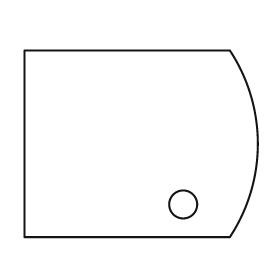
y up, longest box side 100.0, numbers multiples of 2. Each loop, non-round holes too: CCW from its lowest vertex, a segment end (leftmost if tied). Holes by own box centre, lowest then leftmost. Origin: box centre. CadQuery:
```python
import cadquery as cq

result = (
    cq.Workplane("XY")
    .moveTo(-50.0, -40.0)
    .lineTo(38.0, -40.0)
    .threePointArc((50.0, 0.0), (38.0, 40.0))
    .lineTo(-50.0, 40.0)
    .close()
    .moveTo(18.0, -26.0)
    .circle(6.0)
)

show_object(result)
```